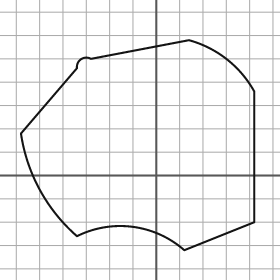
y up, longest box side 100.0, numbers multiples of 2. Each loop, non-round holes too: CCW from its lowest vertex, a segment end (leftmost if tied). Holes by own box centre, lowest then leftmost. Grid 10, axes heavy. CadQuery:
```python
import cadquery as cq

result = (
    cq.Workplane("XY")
    .moveTo(12.0, -32.0)
    .lineTo(42.0, -20.0)
    .lineTo(42.0, 36.0)
    .threePointArc((30.0, 50.0), (14.0, 58.0))
    .lineTo(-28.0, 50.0)
    .threePointArc((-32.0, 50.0), (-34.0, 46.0))
    .lineTo(-58.0, 18.0)
    .threePointArc((-50.0, -6.0), (-34.0, -26.0))
    .threePointArc((-10.0, -22.0), (12.0, -32.0))
    .close()
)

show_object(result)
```